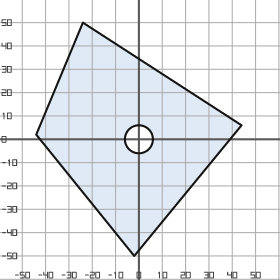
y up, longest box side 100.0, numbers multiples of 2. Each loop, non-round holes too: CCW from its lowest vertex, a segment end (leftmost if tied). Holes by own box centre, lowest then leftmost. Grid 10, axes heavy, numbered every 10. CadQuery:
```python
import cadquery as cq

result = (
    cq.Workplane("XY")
    .moveTo(-2.0, -50.0)
    .lineTo(44.0, 6.0)
    .lineTo(-24.0, 50.0)
    .lineTo(-44.0, 2.0)
    .close()
    .moveTo(0.0, 0.0)
    .circle(6.0)
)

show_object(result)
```